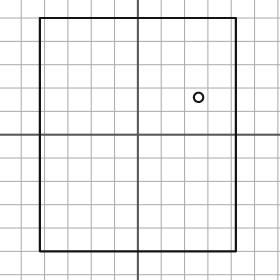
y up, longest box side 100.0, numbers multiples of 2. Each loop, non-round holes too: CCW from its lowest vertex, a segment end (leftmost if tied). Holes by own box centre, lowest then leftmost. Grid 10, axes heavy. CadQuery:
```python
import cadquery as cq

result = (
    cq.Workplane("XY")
    .moveTo(-42.0, -50.0)
    .lineTo(42.0, -50.0)
    .lineTo(42.0, 50.0)
    .lineTo(-42.0, 50.0)
    .close()
    .moveTo(26.0, 16.0)
    .circle(2.0)
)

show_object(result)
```